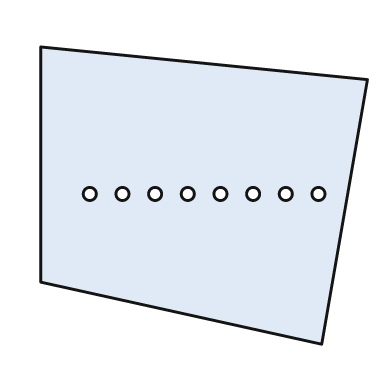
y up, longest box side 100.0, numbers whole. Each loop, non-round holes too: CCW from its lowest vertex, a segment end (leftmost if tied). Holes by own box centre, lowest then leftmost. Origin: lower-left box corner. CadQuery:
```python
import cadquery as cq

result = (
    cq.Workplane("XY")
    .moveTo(86.0, 0.0)
    .lineTo(100.0, 81.0)
    .lineTo(0.0, 91.0)
    .lineTo(0.0, 19.0)
    .close()
    .moveTo(15.0, 46.0)
    .circle(2.0)
    .moveTo(25.0, 46.0)
    .circle(2.0)
    .moveTo(35.0, 46.0)
    .circle(2.0)
    .moveTo(45.0, 46.0)
    .circle(2.0)
    .moveTo(55.0, 46.0)
    .circle(2.0)
    .moveTo(65.0, 46.0)
    .circle(2.0)
    .moveTo(75.0, 46.0)
    .circle(2.0)
    .moveTo(85.0, 46.0)
    .circle(2.0)
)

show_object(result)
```